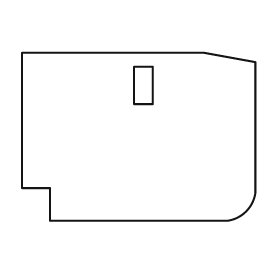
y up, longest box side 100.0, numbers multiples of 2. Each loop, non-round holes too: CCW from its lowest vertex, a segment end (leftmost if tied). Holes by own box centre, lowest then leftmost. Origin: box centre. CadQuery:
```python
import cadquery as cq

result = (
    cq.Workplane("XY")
    .moveTo(-38.0, -36.0)
    .lineTo(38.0, -36.0)
    .threePointArc((46.0, -32.0), (50.0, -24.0))
    .lineTo(50.0, 32.0)
    .lineTo(28.0, 36.0)
    .lineTo(-50.0, 36.0)
    .lineTo(-50.0, -22.0)
    .lineTo(-38.0, -22.0)
    .close()
    .moveTo(-2.0, 14.0)
    .lineTo(6.0, 14.0)
    .lineTo(6.0, 30.0)
    .lineTo(-2.0, 30.0)
    .close()
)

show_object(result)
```